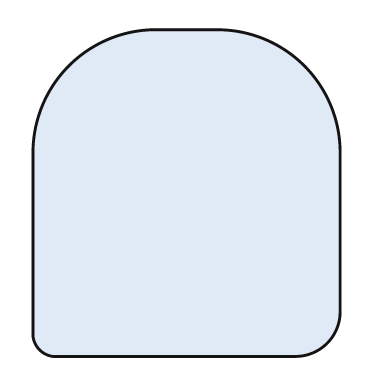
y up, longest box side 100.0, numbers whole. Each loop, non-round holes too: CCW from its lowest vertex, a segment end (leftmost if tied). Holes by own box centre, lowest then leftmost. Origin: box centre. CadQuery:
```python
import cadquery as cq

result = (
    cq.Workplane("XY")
    .moveTo(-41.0, -50.0)
    .lineTo(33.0, -50.0)
    .threePointArc((43.0, -46.0), (47.0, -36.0))
    .lineTo(47.0, 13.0)
    .threePointArc((36.0, 39.0), (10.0, 50.0))
    .lineTo(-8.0, 50.0)
    .threePointArc((-36.0, 39.0), (-47.0, 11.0))
    .lineTo(-47.0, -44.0)
    .threePointArc((-45.0, -48.0), (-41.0, -50.0))
    .close()
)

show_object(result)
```